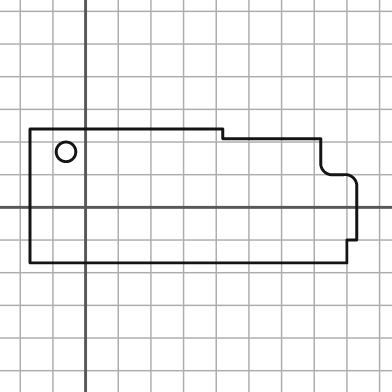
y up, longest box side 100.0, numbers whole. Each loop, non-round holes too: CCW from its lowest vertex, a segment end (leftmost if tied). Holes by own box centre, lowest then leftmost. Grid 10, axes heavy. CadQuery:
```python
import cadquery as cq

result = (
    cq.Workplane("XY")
    .moveTo(-17.0, -17.0)
    .lineTo(80.0, -17.0)
    .lineTo(80.0, -10.0)
    .lineTo(83.0, -10.0)
    .lineTo(83.0, 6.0)
    .threePointArc((82.0, 9.0), (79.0, 10.0))
    .lineTo(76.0, 10.0)
    .threePointArc((73.0, 11.0), (72.0, 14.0))
    .lineTo(72.0, 21.0)
    .lineTo(42.0, 21.0)
    .lineTo(42.0, 24.0)
    .lineTo(-17.0, 24.0)
    .close()
    .moveTo(-6.0, 17.0)
    .circle(3.0)
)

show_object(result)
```